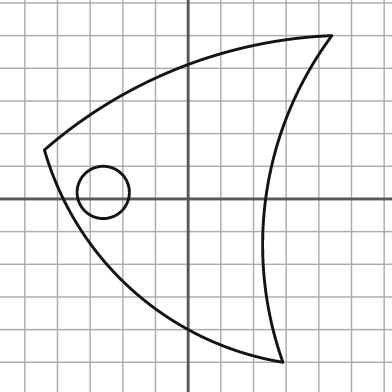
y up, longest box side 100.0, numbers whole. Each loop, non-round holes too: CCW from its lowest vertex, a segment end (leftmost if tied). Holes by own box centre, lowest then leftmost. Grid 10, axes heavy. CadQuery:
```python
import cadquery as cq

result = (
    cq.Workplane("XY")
    .moveTo(29.0, -50.0)
    .threePointArc((24.0, 2.0), (44.0, 50.0))
    .threePointArc((-3.0, 40.0), (-44.0, 15.0))
    .threePointArc((-17.0, -28.0), (29.0, -50.0))
    .close()
    .moveTo(-26.0, 2.0)
    .circle(8.0)
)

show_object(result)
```